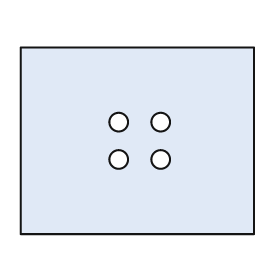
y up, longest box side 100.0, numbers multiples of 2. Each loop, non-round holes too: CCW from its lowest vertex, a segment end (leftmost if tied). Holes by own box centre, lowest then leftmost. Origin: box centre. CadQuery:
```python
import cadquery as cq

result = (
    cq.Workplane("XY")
    .moveTo(-50.0, -40.0)
    .lineTo(50.0, -40.0)
    .lineTo(50.0, 40.0)
    .lineTo(-50.0, 40.0)
    .close()
    .moveTo(-8.0, -8.0)
    .circle(4.0)
    .moveTo(10.0, -8.0)
    .circle(4.0)
    .moveTo(-8.0, 8.0)
    .circle(4.0)
    .moveTo(10.0, 8.0)
    .circle(4.0)
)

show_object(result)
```